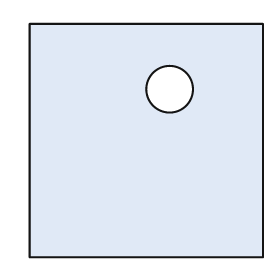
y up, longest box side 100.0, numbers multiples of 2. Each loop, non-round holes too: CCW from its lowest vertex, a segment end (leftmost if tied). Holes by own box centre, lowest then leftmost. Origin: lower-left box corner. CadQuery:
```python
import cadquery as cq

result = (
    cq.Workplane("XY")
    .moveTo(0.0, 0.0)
    .lineTo(100.0, 0.0)
    .lineTo(100.0, 100.0)
    .lineTo(0.0, 100.0)
    .close()
    .moveTo(60.0, 72.0)
    .circle(10.0)
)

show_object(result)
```